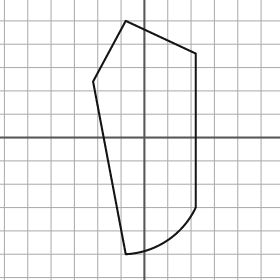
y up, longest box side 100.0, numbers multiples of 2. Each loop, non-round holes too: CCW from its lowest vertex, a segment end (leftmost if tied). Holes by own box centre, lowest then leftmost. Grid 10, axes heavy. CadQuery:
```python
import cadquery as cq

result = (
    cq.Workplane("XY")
    .moveTo(-8.0, -50.0)
    .threePointArc((10.0, -44.0), (22.0, -30.0))
    .lineTo(22.0, 36.0)
    .lineTo(-8.0, 50.0)
    .lineTo(-22.0, 24.0)
    .close()
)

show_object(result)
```